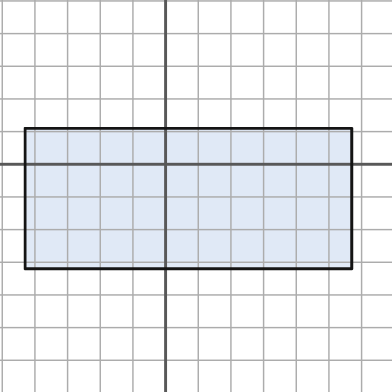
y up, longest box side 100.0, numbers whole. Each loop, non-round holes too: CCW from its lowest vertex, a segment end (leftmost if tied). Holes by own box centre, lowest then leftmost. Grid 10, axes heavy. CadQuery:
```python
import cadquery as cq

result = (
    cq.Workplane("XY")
    .moveTo(-43.0, -32.0)
    .lineTo(57.0, -32.0)
    .lineTo(57.0, 11.0)
    .lineTo(-43.0, 11.0)
    .close()
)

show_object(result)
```